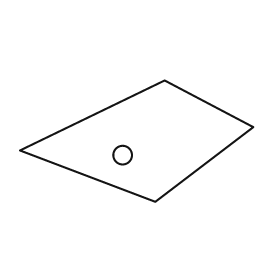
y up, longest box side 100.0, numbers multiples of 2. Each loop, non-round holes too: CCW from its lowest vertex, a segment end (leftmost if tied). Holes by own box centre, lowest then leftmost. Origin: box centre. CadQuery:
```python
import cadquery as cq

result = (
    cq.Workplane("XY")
    .moveTo(8.0, -26.0)
    .lineTo(50.0, 6.0)
    .lineTo(12.0, 26.0)
    .lineTo(-50.0, -4.0)
    .close()
    .moveTo(-6.0, -6.0)
    .circle(4.0)
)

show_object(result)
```